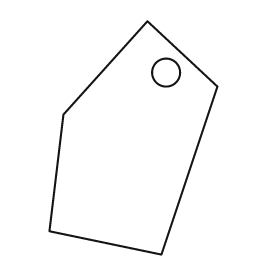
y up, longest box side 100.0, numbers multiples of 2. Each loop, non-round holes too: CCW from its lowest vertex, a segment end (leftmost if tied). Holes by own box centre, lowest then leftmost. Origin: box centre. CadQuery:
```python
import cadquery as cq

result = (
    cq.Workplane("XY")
    .moveTo(12.0, -50.0)
    .lineTo(36.0, 22.0)
    .lineTo(6.0, 50.0)
    .lineTo(-30.0, 10.0)
    .lineTo(-36.0, -40.0)
    .close()
    .moveTo(14.0, 28.0)
    .circle(6.0)
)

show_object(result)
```